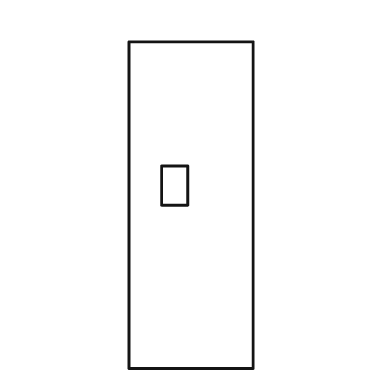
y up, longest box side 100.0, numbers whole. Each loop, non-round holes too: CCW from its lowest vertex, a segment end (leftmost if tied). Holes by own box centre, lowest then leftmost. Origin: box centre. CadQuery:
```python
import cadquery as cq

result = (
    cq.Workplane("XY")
    .moveTo(-19.0, -50.0)
    .lineTo(19.0, -50.0)
    .lineTo(19.0, 50.0)
    .lineTo(-19.0, 50.0)
    .close()
    .moveTo(-9.0, 0.0)
    .lineTo(-1.0, 0.0)
    .lineTo(-1.0, 12.0)
    .lineTo(-9.0, 12.0)
    .close()
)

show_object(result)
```